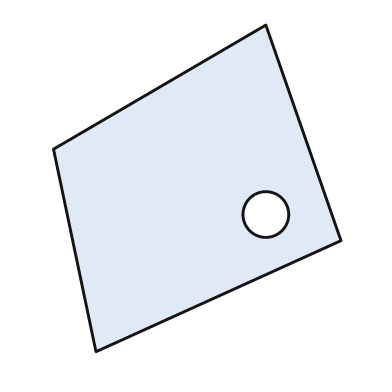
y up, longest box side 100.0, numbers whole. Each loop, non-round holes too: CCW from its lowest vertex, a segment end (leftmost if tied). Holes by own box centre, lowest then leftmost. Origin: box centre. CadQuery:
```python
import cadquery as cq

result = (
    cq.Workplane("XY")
    .moveTo(-31.0, -50.0)
    .lineTo(44.0, -16.0)
    .lineTo(21.0, 50.0)
    .lineTo(-44.0, 12.0)
    .close()
    .moveTo(21.0, -8.0)
    .circle(7.0)
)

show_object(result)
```